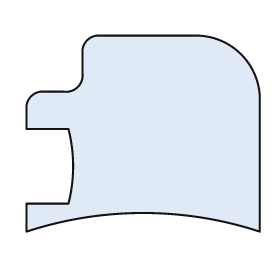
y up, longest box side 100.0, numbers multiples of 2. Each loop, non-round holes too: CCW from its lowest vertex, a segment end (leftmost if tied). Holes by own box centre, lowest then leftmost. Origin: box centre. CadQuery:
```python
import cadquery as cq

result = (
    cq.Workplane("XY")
    .moveTo(-50.0, -42.0)
    .threePointArc((0.0, -34.0), (50.0, -42.0))
    .lineTo(50.0, 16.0)
    .threePointArc((42.0, 34.0), (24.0, 42.0))
    .lineTo(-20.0, 42.0)
    .threePointArc((-24.0, 40.0), (-26.0, 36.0))
    .lineTo(-26.0, 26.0)
    .threePointArc((-28.0, 20.0), (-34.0, 18.0))
    .lineTo(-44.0, 18.0)
    .threePointArc((-48.0, 16.0), (-50.0, 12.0))
    .lineTo(-50.0, 2.0)
    .lineTo(-32.0, 2.0)
    .threePointArc((-30.0, -14.0), (-32.0, -30.0))
    .lineTo(-50.0, -30.0)
    .close()
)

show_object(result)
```